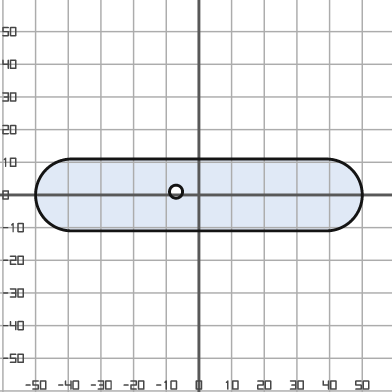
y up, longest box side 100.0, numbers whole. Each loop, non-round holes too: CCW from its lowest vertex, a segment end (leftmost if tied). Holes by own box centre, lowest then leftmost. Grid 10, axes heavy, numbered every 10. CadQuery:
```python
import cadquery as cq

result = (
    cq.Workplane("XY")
    .moveTo(-39.0, -11.0)
    .lineTo(39.0, -11.0)
    .threePointArc((50.0, 0.0), (39.0, 11.0))
    .lineTo(-39.0, 11.0)
    .threePointArc((-50.0, 0.0), (-39.0, -11.0))
    .close()
    .moveTo(-7.0, 1.0)
    .circle(2.0)
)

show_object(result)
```